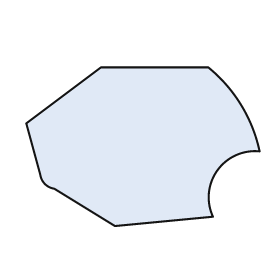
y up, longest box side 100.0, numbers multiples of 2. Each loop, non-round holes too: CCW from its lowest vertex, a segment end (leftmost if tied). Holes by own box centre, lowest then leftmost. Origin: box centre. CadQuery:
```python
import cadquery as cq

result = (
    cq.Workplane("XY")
    .moveTo(-12.0, -34.0)
    .lineTo(30.0, -30.0)
    .threePointArc((32.0, -10.0), (50.0, -2.0))
    .threePointArc((42.0, 18.0), (28.0, 34.0))
    .lineTo(-18.0, 34.0)
    .lineTo(-50.0, 10.0)
    .lineTo(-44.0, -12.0)
    .threePointArc((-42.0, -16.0), (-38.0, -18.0))
    .close()
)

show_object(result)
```